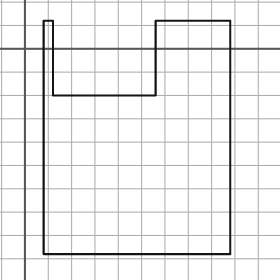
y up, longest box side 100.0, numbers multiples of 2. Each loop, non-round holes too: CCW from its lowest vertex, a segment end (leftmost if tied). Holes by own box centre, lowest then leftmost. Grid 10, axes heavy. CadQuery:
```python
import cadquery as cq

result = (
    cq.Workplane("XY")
    .moveTo(8.0, -88.0)
    .lineTo(88.0, -88.0)
    .lineTo(88.0, 12.0)
    .lineTo(56.0, 12.0)
    .lineTo(56.0, -20.0)
    .lineTo(12.0, -20.0)
    .lineTo(12.0, 12.0)
    .lineTo(8.0, 12.0)
    .close()
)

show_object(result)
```